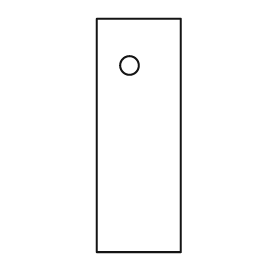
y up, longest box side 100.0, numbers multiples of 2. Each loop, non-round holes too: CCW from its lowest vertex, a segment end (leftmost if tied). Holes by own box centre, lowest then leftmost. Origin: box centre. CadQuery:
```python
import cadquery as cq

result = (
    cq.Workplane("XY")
    .moveTo(-18.0, -50.0)
    .lineTo(18.0, -50.0)
    .lineTo(18.0, 50.0)
    .lineTo(-18.0, 50.0)
    .close()
    .moveTo(-4.0, 30.0)
    .circle(4.0)
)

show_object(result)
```